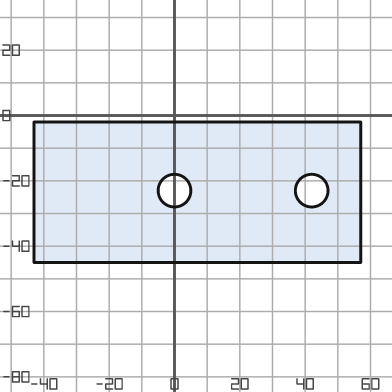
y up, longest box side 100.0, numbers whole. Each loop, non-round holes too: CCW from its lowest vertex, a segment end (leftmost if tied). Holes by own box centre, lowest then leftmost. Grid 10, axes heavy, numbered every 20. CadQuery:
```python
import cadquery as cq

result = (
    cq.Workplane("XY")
    .moveTo(-43.0, -45.0)
    .lineTo(57.0, -45.0)
    .lineTo(57.0, -2.0)
    .lineTo(-43.0, -2.0)
    .close()
    .moveTo(0.0, -23.0)
    .circle(5.0)
    .moveTo(42.0, -23.0)
    .circle(5.0)
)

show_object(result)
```